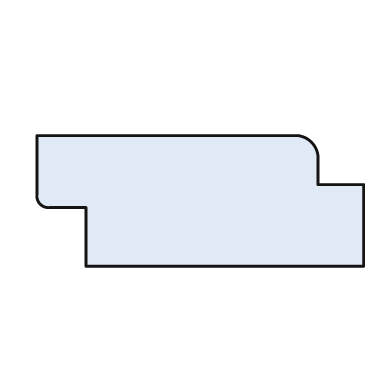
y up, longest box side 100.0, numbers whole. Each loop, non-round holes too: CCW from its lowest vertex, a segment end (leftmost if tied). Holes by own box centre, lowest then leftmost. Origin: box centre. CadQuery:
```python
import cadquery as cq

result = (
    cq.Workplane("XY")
    .moveTo(-35.0, -20.0)
    .lineTo(50.0, -20.0)
    .lineTo(50.0, 5.0)
    .lineTo(36.0, 5.0)
    .lineTo(36.0, 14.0)
    .threePointArc((34.0, 18.0), (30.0, 20.0))
    .lineTo(-50.0, 20.0)
    .lineTo(-50.0, 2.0)
    .threePointArc((-49.0, -1.0), (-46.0, -2.0))
    .lineTo(-35.0, -2.0)
    .close()
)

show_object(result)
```